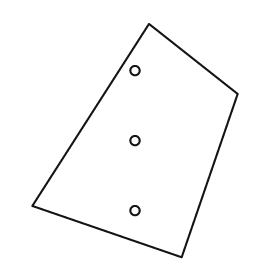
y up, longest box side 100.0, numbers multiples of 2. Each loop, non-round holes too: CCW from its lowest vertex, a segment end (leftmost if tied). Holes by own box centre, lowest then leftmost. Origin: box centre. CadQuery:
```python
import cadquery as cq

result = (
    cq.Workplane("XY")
    .moveTo(20.0, -50.0)
    .lineTo(44.0, 20.0)
    .lineTo(6.0, 50.0)
    .lineTo(-44.0, -28.0)
    .close()
    .moveTo(0.0, -30.0)
    .circle(2.0)
    .moveTo(0.0, 0.0)
    .circle(2.0)
    .moveTo(0.0, 30.0)
    .circle(2.0)
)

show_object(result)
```